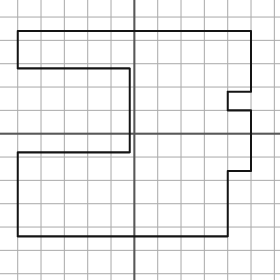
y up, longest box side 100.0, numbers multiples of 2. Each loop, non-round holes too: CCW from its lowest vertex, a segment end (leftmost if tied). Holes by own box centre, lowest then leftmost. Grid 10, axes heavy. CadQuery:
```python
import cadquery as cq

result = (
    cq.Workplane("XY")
    .moveTo(-50.0, -44.0)
    .lineTo(40.0, -44.0)
    .lineTo(40.0, -16.0)
    .lineTo(50.0, -16.0)
    .lineTo(50.0, 10.0)
    .lineTo(40.0, 10.0)
    .lineTo(40.0, 18.0)
    .lineTo(50.0, 18.0)
    .lineTo(50.0, 44.0)
    .lineTo(-50.0, 44.0)
    .lineTo(-50.0, 28.0)
    .lineTo(-2.0, 28.0)
    .lineTo(-2.0, -8.0)
    .lineTo(-50.0, -8.0)
    .close()
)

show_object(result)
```